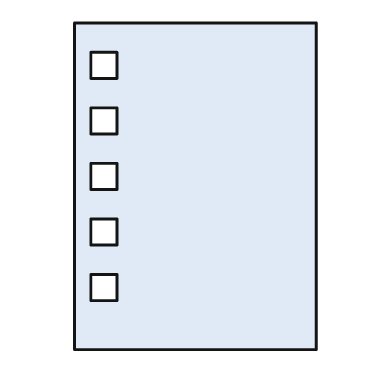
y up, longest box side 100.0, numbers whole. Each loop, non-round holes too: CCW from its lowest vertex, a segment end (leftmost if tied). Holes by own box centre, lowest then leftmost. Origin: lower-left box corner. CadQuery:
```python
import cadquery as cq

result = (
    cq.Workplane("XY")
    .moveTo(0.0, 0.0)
    .lineTo(74.0, 0.0)
    .lineTo(74.0, 100.0)
    .lineTo(0.0, 100.0)
    .close()
    .moveTo(5.0, 15.0)
    .lineTo(13.0, 15.0)
    .lineTo(13.0, 23.0)
    .lineTo(5.0, 23.0)
    .close()
    .moveTo(5.0, 32.0)
    .lineTo(13.0, 32.0)
    .lineTo(13.0, 40.0)
    .lineTo(5.0, 40.0)
    .close()
    .moveTo(5.0, 49.0)
    .lineTo(13.0, 49.0)
    .lineTo(13.0, 57.0)
    .lineTo(5.0, 57.0)
    .close()
    .moveTo(5.0, 66.0)
    .lineTo(13.0, 66.0)
    .lineTo(13.0, 74.0)
    .lineTo(5.0, 74.0)
    .close()
    .moveTo(5.0, 83.0)
    .lineTo(13.0, 83.0)
    .lineTo(13.0, 91.0)
    .lineTo(5.0, 91.0)
    .close()
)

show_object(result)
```